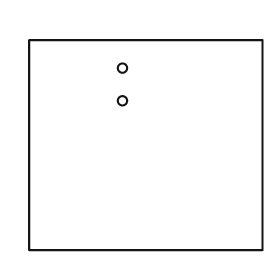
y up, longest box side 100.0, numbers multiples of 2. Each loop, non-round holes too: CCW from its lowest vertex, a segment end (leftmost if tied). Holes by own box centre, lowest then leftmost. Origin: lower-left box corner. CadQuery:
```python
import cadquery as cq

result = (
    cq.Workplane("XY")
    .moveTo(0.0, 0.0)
    .lineTo(100.0, 0.0)
    .lineTo(100.0, 90.0)
    .lineTo(0.0, 90.0)
    .close()
    .moveTo(40.0, 64.0)
    .circle(2.0)
    .moveTo(40.0, 78.0)
    .circle(2.0)
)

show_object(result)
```